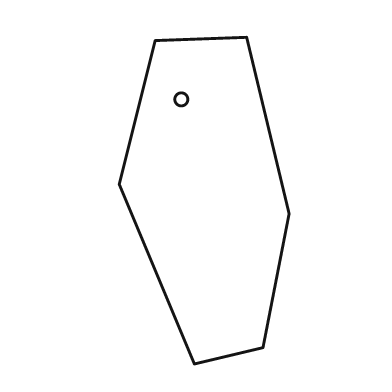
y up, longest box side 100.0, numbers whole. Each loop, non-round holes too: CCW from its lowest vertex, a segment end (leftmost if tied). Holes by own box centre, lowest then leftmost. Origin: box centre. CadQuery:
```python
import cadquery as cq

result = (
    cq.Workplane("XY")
    .moveTo(-3.0, -50.0)
    .lineTo(18.0, -45.0)
    .lineTo(26.0, -4.0)
    .lineTo(13.0, 50.0)
    .lineTo(-15.0, 49.0)
    .lineTo(-26.0, 5.0)
    .close()
    .moveTo(-7.0, 31.0)
    .circle(2.0)
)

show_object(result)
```